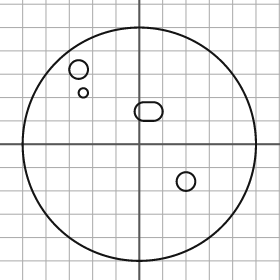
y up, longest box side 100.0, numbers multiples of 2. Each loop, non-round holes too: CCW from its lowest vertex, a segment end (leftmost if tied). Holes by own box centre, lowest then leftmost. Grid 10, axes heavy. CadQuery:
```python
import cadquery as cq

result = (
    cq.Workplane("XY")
    .moveTo(0.0, 0.0)
    .circle(50.0)
    .moveTo(20.0, -16.0)
    .circle(4.0)
    .moveTo(2.0, 10.0)
    .lineTo(6.0, 10.0)
    .threePointArc((10.0, 14.0), (6.0, 18.0))
    .lineTo(2.0, 18.0)
    .threePointArc((-2.0, 14.0), (2.0, 10.0))
    .close()
    .moveTo(-24.0, 22.0)
    .circle(2.0)
    .moveTo(-26.0, 32.0)
    .circle(4.0)
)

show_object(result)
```